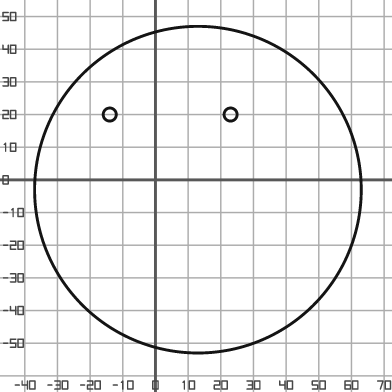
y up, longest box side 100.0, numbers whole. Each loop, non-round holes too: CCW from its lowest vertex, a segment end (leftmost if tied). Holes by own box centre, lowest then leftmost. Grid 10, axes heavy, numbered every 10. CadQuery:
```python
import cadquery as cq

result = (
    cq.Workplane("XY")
    .moveTo(13.0, -3.0)
    .circle(50.0)
    .moveTo(-14.0, 20.0)
    .circle(2.0)
    .moveTo(23.0, 20.0)
    .circle(2.0)
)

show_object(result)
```